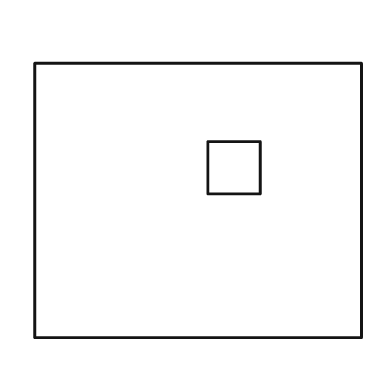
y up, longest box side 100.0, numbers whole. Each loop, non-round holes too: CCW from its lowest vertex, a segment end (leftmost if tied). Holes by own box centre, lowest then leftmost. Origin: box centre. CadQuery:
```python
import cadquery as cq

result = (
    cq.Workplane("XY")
    .moveTo(-50.0, -42.0)
    .lineTo(50.0, -42.0)
    .lineTo(50.0, 42.0)
    .lineTo(-50.0, 42.0)
    .close()
    .moveTo(3.0, 2.0)
    .lineTo(19.0, 2.0)
    .lineTo(19.0, 18.0)
    .lineTo(3.0, 18.0)
    .close()
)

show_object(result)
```